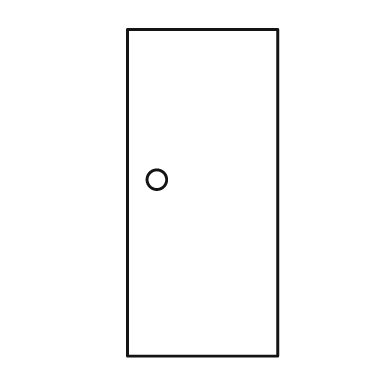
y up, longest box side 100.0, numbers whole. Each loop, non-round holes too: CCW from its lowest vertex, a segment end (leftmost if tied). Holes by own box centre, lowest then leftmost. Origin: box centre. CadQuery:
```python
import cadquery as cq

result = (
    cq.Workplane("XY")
    .moveTo(-23.0, -50.0)
    .lineTo(23.0, -50.0)
    .lineTo(23.0, 50.0)
    .lineTo(-23.0, 50.0)
    .close()
    .moveTo(-14.0, 4.0)
    .circle(3.0)
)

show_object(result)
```